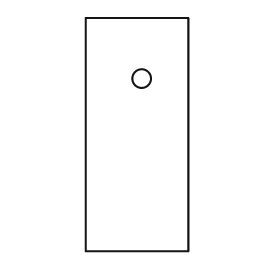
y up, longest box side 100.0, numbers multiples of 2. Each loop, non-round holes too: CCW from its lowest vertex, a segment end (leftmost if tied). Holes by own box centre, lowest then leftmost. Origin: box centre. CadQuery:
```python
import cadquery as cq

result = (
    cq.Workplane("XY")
    .moveTo(-22.0, -50.0)
    .lineTo(22.0, -50.0)
    .lineTo(22.0, 50.0)
    .lineTo(-22.0, 50.0)
    .close()
    .moveTo(2.0, 24.0)
    .circle(4.0)
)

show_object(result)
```